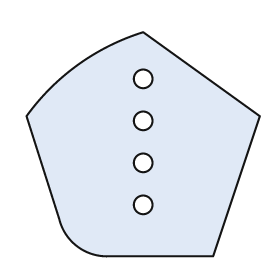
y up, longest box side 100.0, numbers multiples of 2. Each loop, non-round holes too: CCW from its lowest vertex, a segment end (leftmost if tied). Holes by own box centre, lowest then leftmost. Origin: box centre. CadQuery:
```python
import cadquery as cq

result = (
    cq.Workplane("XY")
    .moveTo(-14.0, -48.0)
    .lineTo(30.0, -48.0)
    .lineTo(50.0, 12.0)
    .lineTo(0.0, 48.0)
    .threePointArc((-28.0, 34.0), (-50.0, 12.0))
    .lineTo(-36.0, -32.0)
    .threePointArc((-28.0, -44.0), (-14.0, -48.0))
    .close()
    .moveTo(0.0, -26.0)
    .circle(4.0)
    .moveTo(0.0, -8.0)
    .circle(4.0)
    .moveTo(0.0, 10.0)
    .circle(4.0)
    .moveTo(0.0, 28.0)
    .circle(4.0)
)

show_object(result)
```